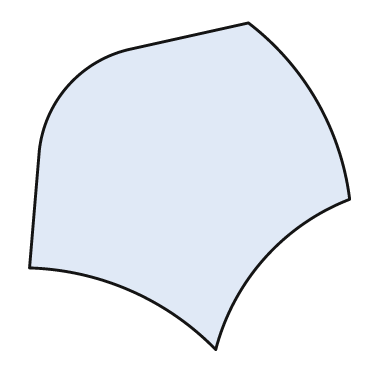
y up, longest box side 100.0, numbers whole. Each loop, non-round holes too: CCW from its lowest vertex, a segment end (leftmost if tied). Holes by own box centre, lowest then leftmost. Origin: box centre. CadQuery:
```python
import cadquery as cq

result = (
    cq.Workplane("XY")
    .moveTo(8.0, -50.0)
    .threePointArc((23.0, -22.0), (49.0, -4.0))
    .threePointArc((39.0, 26.0), (18.0, 50.0))
    .lineTo(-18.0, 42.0)
    .threePointArc((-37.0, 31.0), (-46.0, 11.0))
    .lineTo(-49.0, -25.0)
    .threePointArc((-18.0, -32.0), (8.0, -50.0))
    .close()
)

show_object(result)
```